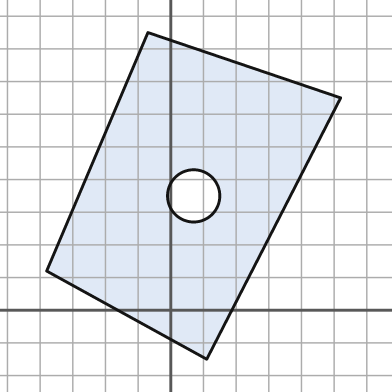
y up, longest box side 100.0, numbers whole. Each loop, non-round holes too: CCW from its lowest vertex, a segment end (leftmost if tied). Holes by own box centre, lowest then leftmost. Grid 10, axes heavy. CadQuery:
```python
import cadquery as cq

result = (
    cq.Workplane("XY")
    .moveTo(11.0, -15.0)
    .lineTo(52.0, 65.0)
    .lineTo(-7.0, 85.0)
    .lineTo(-38.0, 12.0)
    .close()
    .moveTo(7.0, 35.0)
    .circle(8.0)
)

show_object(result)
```